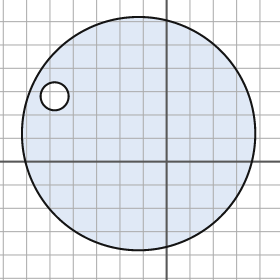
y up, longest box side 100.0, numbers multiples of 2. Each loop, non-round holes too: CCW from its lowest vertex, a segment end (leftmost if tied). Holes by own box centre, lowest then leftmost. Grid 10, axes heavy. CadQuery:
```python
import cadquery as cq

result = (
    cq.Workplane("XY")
    .moveTo(-12.0, 12.0)
    .circle(50.0)
    .moveTo(-48.0, 28.0)
    .circle(6.0)
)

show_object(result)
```